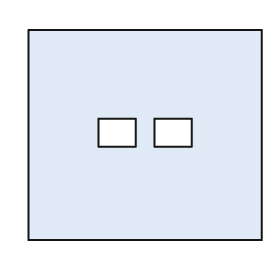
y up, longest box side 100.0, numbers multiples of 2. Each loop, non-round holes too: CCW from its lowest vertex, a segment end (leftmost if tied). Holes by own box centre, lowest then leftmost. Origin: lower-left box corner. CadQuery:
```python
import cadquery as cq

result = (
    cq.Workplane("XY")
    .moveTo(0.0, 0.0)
    .lineTo(100.0, 0.0)
    .lineTo(100.0, 90.0)
    .lineTo(0.0, 90.0)
    .close()
    .moveTo(30.0, 40.0)
    .lineTo(46.0, 40.0)
    .lineTo(46.0, 52.0)
    .lineTo(30.0, 52.0)
    .close()
    .moveTo(54.0, 40.0)
    .lineTo(70.0, 40.0)
    .lineTo(70.0, 52.0)
    .lineTo(54.0, 52.0)
    .close()
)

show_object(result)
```